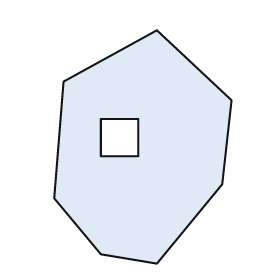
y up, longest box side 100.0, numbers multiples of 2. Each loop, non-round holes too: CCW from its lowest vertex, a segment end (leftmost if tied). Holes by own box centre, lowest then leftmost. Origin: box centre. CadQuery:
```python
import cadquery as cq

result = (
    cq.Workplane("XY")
    .moveTo(6.0, -50.0)
    .lineTo(34.0, -16.0)
    .lineTo(38.0, 20.0)
    .lineTo(6.0, 50.0)
    .lineTo(-34.0, 28.0)
    .lineTo(-38.0, -22.0)
    .lineTo(-18.0, -46.0)
    .close()
    .moveTo(-18.0, -4.0)
    .lineTo(-2.0, -4.0)
    .lineTo(-2.0, 12.0)
    .lineTo(-18.0, 12.0)
    .close()
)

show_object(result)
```